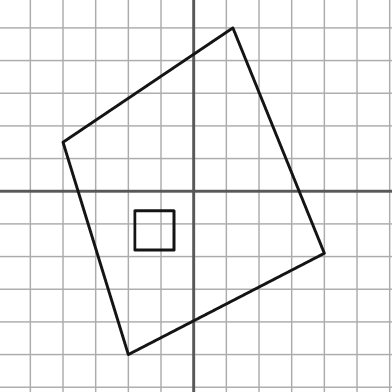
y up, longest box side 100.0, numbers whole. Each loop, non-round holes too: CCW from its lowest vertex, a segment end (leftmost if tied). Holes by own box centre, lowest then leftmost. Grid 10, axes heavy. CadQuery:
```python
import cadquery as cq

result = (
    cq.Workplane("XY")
    .moveTo(-20.0, -50.0)
    .lineTo(40.0, -19.0)
    .lineTo(12.0, 50.0)
    .lineTo(-40.0, 15.0)
    .close()
    .moveTo(-18.0, -18.0)
    .lineTo(-6.0, -18.0)
    .lineTo(-6.0, -6.0)
    .lineTo(-18.0, -6.0)
    .close()
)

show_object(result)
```